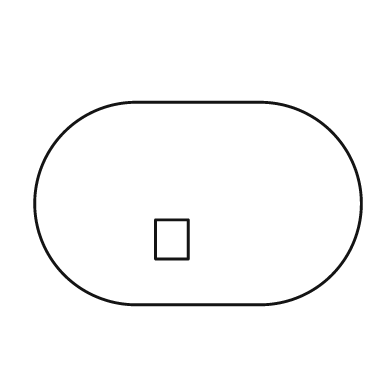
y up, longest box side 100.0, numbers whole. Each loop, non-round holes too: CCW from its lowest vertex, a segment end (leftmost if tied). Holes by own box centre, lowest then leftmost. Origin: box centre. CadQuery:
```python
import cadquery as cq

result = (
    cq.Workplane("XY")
    .moveTo(-19.0, -31.0)
    .lineTo(19.0, -31.0)
    .threePointArc((50.0, 0.0), (19.0, 31.0))
    .lineTo(-19.0, 31.0)
    .threePointArc((-50.0, 0.0), (-19.0, -31.0))
    .close()
    .moveTo(-13.0, -17.0)
    .lineTo(-3.0, -17.0)
    .lineTo(-3.0, -5.0)
    .lineTo(-13.0, -5.0)
    .close()
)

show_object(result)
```